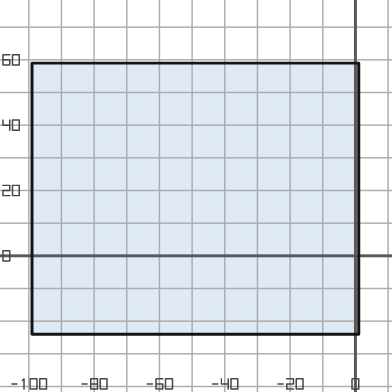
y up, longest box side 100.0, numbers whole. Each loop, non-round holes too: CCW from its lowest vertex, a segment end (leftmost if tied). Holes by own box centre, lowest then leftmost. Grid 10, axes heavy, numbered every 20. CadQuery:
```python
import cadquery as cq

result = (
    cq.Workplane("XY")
    .moveTo(-99.0, -24.0)
    .lineTo(1.0, -24.0)
    .lineTo(1.0, 59.0)
    .lineTo(-99.0, 59.0)
    .close()
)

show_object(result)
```